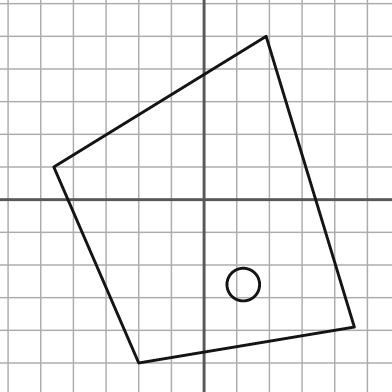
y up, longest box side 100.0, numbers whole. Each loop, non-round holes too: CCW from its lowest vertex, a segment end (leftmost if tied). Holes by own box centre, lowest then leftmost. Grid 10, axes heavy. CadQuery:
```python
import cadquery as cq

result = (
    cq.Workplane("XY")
    .moveTo(-20.0, -50.0)
    .lineTo(46.0, -39.0)
    .lineTo(19.0, 50.0)
    .lineTo(-46.0, 10.0)
    .close()
    .moveTo(12.0, -26.0)
    .circle(5.0)
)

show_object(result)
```